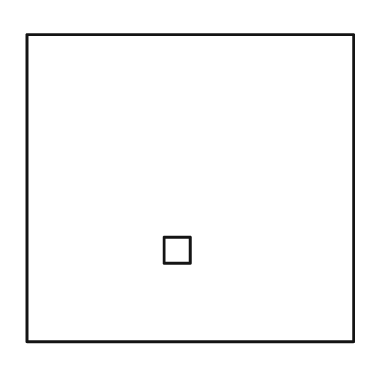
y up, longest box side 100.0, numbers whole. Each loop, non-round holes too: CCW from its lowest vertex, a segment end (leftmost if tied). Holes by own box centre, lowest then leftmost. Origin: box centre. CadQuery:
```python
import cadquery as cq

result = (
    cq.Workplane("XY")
    .moveTo(-50.0, -47.0)
    .lineTo(50.0, -47.0)
    .lineTo(50.0, 47.0)
    .lineTo(-50.0, 47.0)
    .close()
    .moveTo(-8.0, -23.0)
    .lineTo(0.0, -23.0)
    .lineTo(0.0, -15.0)
    .lineTo(-8.0, -15.0)
    .close()
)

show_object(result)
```